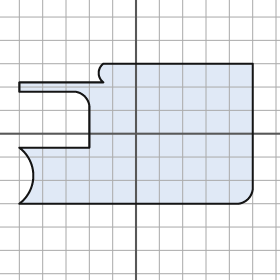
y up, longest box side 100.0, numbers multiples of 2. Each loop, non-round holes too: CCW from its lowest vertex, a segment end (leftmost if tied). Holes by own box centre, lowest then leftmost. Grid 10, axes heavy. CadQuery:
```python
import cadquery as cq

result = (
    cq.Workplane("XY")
    .moveTo(-50.0, -30.0)
    .lineTo(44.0, -30.0)
    .threePointArc((48.0, -28.0), (50.0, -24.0))
    .lineTo(50.0, 30.0)
    .lineTo(-14.0, 30.0)
    .threePointArc((-16.0, 26.0), (-14.0, 22.0))
    .lineTo(-50.0, 22.0)
    .lineTo(-50.0, 18.0)
    .lineTo(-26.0, 18.0)
    .threePointArc((-22.0, 16.0), (-20.0, 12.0))
    .lineTo(-20.0, -6.0)
    .lineTo(-50.0, -6.0)
    .threePointArc((-44.0, -18.0), (-50.0, -30.0))
    .close()
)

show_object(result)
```